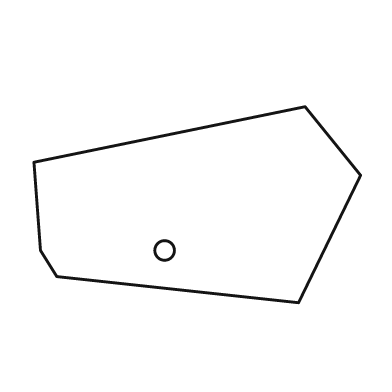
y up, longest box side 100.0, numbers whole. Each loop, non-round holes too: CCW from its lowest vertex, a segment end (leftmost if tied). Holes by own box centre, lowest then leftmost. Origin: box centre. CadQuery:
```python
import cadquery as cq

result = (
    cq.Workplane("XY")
    .moveTo(31.0, -30.0)
    .lineTo(50.0, 9.0)
    .lineTo(33.0, 30.0)
    .lineTo(-50.0, 13.0)
    .lineTo(-48.0, -14.0)
    .lineTo(-43.0, -22.0)
    .close()
    .moveTo(-10.0, -14.0)
    .circle(3.0)
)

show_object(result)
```